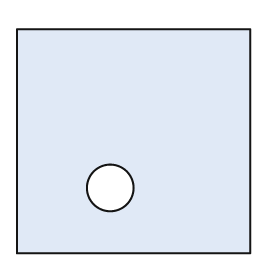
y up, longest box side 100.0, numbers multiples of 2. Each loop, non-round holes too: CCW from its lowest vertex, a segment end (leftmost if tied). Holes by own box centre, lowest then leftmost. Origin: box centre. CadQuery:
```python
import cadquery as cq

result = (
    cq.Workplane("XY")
    .moveTo(-50.0, -48.0)
    .lineTo(50.0, -48.0)
    .lineTo(50.0, 48.0)
    .lineTo(-50.0, 48.0)
    .close()
    .moveTo(-10.0, -20.0)
    .circle(10.0)
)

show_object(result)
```